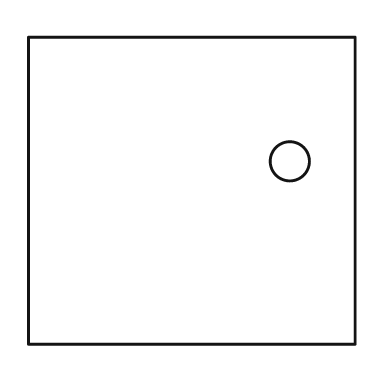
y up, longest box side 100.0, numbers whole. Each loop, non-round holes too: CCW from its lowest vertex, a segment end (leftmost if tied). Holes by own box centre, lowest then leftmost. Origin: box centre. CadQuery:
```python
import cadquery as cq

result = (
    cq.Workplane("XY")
    .moveTo(-50.0, -47.0)
    .lineTo(50.0, -47.0)
    .lineTo(50.0, 47.0)
    .lineTo(-50.0, 47.0)
    .close()
    .moveTo(30.0, 9.0)
    .circle(6.0)
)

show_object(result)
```